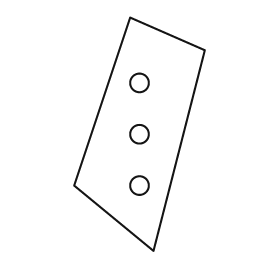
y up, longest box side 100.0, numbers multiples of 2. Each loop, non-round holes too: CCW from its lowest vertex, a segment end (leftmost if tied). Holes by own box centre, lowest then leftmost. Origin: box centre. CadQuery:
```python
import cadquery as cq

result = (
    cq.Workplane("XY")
    .moveTo(6.0, -50.0)
    .lineTo(28.0, 36.0)
    .lineTo(-4.0, 50.0)
    .lineTo(-28.0, -22.0)
    .close()
    .moveTo(0.0, -22.0)
    .circle(4.0)
    .moveTo(0.0, 0.0)
    .circle(4.0)
    .moveTo(0.0, 22.0)
    .circle(4.0)
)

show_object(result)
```